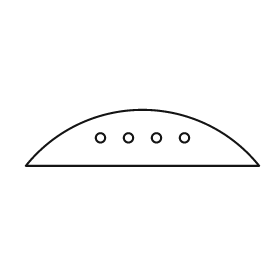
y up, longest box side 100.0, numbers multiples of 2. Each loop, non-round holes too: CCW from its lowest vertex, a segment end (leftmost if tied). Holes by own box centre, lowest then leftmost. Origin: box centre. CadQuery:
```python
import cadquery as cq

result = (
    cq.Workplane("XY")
    .moveTo(-50.0, -12.0)
    .lineTo(50.0, -12.0)
    .threePointArc((0.0, 12.0), (-50.0, -12.0))
    .close()
    .moveTo(-18.0, 0.0)
    .circle(2.0)
    .moveTo(-6.0, 0.0)
    .circle(2.0)
    .moveTo(6.0, 0.0)
    .circle(2.0)
    .moveTo(18.0, 0.0)
    .circle(2.0)
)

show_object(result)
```